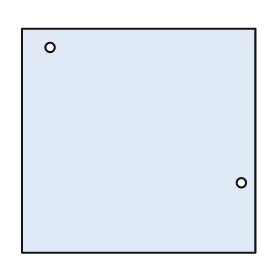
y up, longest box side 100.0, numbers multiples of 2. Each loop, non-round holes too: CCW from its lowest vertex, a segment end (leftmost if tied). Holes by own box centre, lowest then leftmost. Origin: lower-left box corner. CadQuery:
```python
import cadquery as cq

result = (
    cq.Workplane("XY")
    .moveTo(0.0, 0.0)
    .lineTo(100.0, 0.0)
    .lineTo(100.0, 96.0)
    .lineTo(0.0, 96.0)
    .close()
    .moveTo(94.0, 30.0)
    .circle(2.0)
    .moveTo(12.0, 88.0)
    .circle(2.0)
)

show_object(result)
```